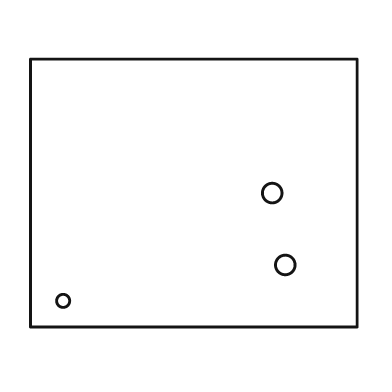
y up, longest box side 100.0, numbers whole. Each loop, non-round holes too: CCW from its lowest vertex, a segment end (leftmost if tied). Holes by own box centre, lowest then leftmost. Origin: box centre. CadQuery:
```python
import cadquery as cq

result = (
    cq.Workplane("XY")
    .moveTo(-50.0, -41.0)
    .lineTo(50.0, -41.0)
    .lineTo(50.0, 41.0)
    .lineTo(-50.0, 41.0)
    .close()
    .moveTo(-40.0, -33.0)
    .circle(2.0)
    .moveTo(28.0, -22.0)
    .circle(3.0)
    .moveTo(24.0, 0.0)
    .circle(3.0)
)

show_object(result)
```